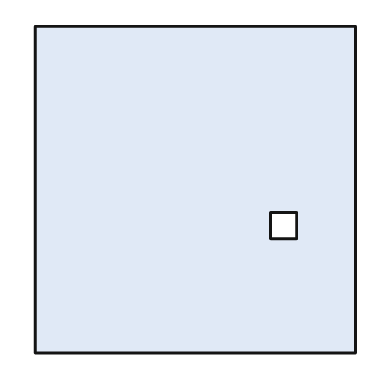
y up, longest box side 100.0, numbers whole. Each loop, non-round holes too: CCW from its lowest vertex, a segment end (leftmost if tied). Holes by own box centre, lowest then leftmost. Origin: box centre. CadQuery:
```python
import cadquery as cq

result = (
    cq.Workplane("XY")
    .moveTo(-49.0, -50.0)
    .lineTo(49.0, -50.0)
    .lineTo(49.0, 50.0)
    .lineTo(-49.0, 50.0)
    .close()
    .moveTo(23.0, -15.0)
    .lineTo(31.0, -15.0)
    .lineTo(31.0, -7.0)
    .lineTo(23.0, -7.0)
    .close()
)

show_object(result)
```